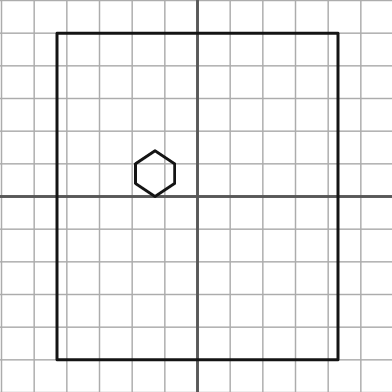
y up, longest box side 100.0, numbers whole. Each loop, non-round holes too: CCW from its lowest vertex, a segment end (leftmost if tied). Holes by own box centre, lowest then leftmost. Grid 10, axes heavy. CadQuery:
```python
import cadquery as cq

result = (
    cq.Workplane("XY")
    .moveTo(-43.0, -50.0)
    .lineTo(43.0, -50.0)
    .lineTo(43.0, 50.0)
    .lineTo(-43.0, 50.0)
    .close()
    .moveTo(-13.0, 0.0)
    .lineTo(-7.0, 4.0)
    .lineTo(-7.0, 10.0)
    .lineTo(-13.0, 14.0)
    .lineTo(-19.0, 10.0)
    .lineTo(-19.0, 4.0)
    .close()
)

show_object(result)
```